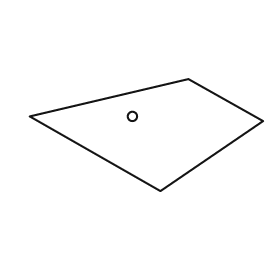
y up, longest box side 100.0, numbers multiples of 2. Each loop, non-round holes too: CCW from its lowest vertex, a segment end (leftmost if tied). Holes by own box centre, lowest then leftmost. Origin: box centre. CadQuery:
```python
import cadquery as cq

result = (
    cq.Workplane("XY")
    .moveTo(6.0, -24.0)
    .lineTo(50.0, 6.0)
    .lineTo(18.0, 24.0)
    .lineTo(-50.0, 8.0)
    .close()
    .moveTo(-6.0, 8.0)
    .circle(2.0)
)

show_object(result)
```